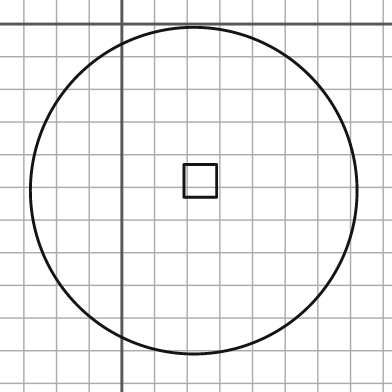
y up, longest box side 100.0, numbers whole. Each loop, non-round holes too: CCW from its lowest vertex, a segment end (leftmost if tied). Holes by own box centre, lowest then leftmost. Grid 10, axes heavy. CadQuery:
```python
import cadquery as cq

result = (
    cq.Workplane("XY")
    .moveTo(22.0, -51.0)
    .circle(50.0)
    .moveTo(19.0, -53.0)
    .lineTo(29.0, -53.0)
    .lineTo(29.0, -43.0)
    .lineTo(19.0, -43.0)
    .close()
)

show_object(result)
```